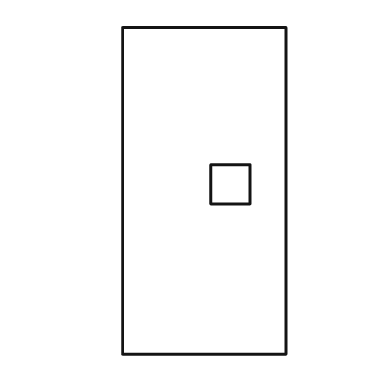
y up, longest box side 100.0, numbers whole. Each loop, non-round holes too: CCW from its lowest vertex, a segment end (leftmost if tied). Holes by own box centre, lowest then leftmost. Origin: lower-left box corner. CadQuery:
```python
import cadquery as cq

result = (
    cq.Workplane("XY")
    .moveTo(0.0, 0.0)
    .lineTo(50.0, 0.0)
    .lineTo(50.0, 100.0)
    .lineTo(0.0, 100.0)
    .close()
    .moveTo(27.0, 46.0)
    .lineTo(39.0, 46.0)
    .lineTo(39.0, 58.0)
    .lineTo(27.0, 58.0)
    .close()
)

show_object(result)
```